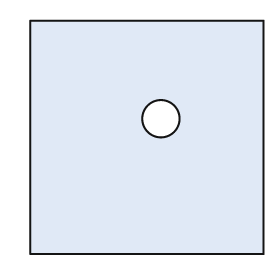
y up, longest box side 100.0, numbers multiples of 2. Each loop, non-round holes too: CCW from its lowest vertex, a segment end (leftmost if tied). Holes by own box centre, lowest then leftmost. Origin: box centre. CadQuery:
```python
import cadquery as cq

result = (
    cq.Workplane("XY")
    .moveTo(-50.0, -50.0)
    .lineTo(50.0, -50.0)
    .lineTo(50.0, 50.0)
    .lineTo(-50.0, 50.0)
    .close()
    .moveTo(6.0, 8.0)
    .circle(8.0)
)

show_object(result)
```